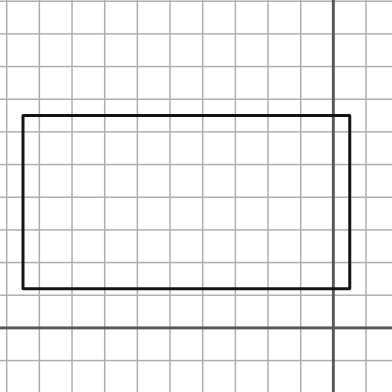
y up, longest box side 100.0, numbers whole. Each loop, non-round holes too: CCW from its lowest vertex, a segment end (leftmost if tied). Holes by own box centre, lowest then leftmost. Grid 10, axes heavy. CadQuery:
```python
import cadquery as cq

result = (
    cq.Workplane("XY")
    .moveTo(-95.0, 12.0)
    .lineTo(5.0, 12.0)
    .lineTo(5.0, 65.0)
    .lineTo(-95.0, 65.0)
    .close()
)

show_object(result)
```